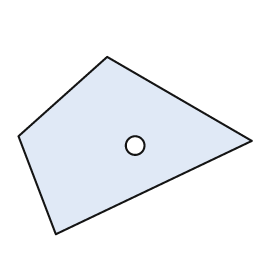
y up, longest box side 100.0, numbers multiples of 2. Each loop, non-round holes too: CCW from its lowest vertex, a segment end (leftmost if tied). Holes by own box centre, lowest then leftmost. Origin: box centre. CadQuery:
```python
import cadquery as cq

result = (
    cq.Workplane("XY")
    .moveTo(-34.0, -38.0)
    .lineTo(50.0, 2.0)
    .lineTo(-12.0, 38.0)
    .lineTo(-50.0, 4.0)
    .close()
    .moveTo(0.0, 0.0)
    .circle(4.0)
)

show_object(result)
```